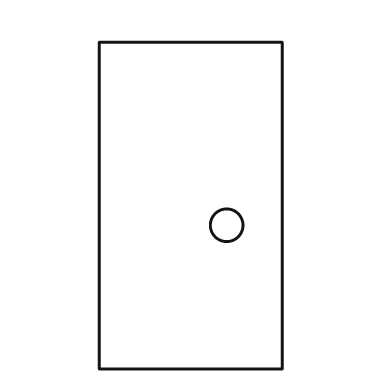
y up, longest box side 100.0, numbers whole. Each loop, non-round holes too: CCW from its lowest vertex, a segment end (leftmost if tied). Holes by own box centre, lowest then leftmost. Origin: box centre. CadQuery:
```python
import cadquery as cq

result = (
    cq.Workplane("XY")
    .moveTo(-28.0, -50.0)
    .lineTo(28.0, -50.0)
    .lineTo(28.0, 50.0)
    .lineTo(-28.0, 50.0)
    .close()
    .moveTo(11.0, -6.0)
    .circle(5.0)
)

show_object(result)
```